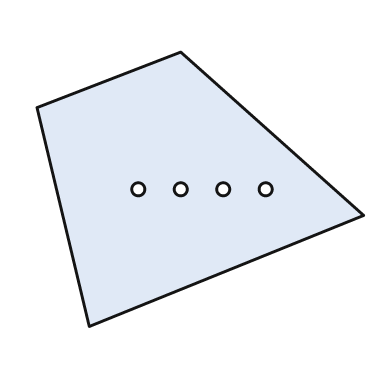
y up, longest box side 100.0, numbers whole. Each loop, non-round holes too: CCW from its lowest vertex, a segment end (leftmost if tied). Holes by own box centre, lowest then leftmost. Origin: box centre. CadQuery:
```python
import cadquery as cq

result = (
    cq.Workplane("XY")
    .moveTo(-34.0, -42.0)
    .lineTo(50.0, -8.0)
    .lineTo(-6.0, 42.0)
    .lineTo(-50.0, 25.0)
    .close()
    .moveTo(-19.0, 0.0)
    .circle(2.0)
    .moveTo(-6.0, 0.0)
    .circle(2.0)
    .moveTo(7.0, 0.0)
    .circle(2.0)
    .moveTo(20.0, 0.0)
    .circle(2.0)
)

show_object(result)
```